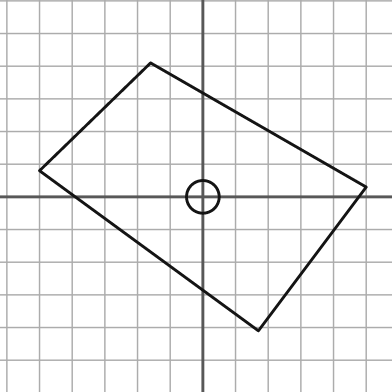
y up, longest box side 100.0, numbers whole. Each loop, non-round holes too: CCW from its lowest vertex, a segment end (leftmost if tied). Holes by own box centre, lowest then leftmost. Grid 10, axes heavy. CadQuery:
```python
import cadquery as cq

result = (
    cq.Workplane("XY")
    .moveTo(17.0, -41.0)
    .lineTo(50.0, 3.0)
    .lineTo(-16.0, 41.0)
    .lineTo(-50.0, 8.0)
    .close()
    .moveTo(0.0, 0.0)
    .circle(5.0)
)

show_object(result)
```